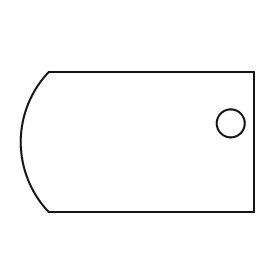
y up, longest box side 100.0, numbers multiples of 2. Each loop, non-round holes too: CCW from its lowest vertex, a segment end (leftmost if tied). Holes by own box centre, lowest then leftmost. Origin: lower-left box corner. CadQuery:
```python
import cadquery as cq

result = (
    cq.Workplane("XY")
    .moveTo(12.0, 0.0)
    .lineTo(100.0, 0.0)
    .lineTo(100.0, 60.0)
    .lineTo(12.0, 60.0)
    .threePointArc((0.0, 30.0), (12.0, 0.0))
    .close()
    .moveTo(90.0, 38.0)
    .circle(6.0)
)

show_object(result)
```